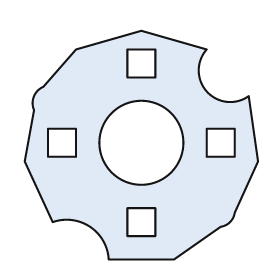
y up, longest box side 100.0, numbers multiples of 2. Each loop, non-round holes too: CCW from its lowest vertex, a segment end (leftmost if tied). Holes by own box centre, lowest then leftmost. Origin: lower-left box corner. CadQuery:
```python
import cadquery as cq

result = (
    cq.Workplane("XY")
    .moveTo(36.0, 0.0)
    .lineTo(64.0, 0.0)
    .lineTo(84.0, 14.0)
    .threePointArc((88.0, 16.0), (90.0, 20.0))
    .lineTo(100.0, 42.0)
    .lineTo(96.0, 70.0)
    .threePointArc((78.0, 72.0), (78.0, 90.0))
    .lineTo(50.0, 98.0)
    .lineTo(22.0, 90.0)
    .lineTo(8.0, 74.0)
    .threePointArc((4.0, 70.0), (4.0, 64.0))
    .lineTo(0.0, 42.0)
    .lineTo(12.0, 16.0)
    .threePointArc((28.0, 14.0), (36.0, 0.0))
    .close()
    .moveTo(44.0, 10.0)
    .lineTo(56.0, 10.0)
    .lineTo(56.0, 22.0)
    .lineTo(44.0, 22.0)
    .close()
    .moveTo(10.0, 44.0)
    .lineTo(22.0, 44.0)
    .lineTo(22.0, 56.0)
    .lineTo(10.0, 56.0)
    .close()
    .moveTo(50.0, 50.0)
    .circle(18.0)
    .moveTo(78.0, 44.0)
    .lineTo(90.0, 44.0)
    .lineTo(90.0, 56.0)
    .lineTo(78.0, 56.0)
    .close()
    .moveTo(44.0, 78.0)
    .lineTo(56.0, 78.0)
    .lineTo(56.0, 90.0)
    .lineTo(44.0, 90.0)
    .close()
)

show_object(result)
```